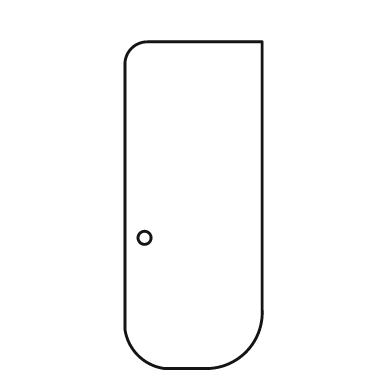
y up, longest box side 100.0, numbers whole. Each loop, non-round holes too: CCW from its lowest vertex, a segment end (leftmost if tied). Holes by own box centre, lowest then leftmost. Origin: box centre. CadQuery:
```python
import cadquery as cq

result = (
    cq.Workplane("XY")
    .moveTo(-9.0, -50.0)
    .lineTo(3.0, -50.0)
    .threePointArc((16.0, -45.0), (21.0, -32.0))
    .lineTo(21.0, 50.0)
    .lineTo(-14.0, 50.0)
    .threePointArc((-19.0, 48.0), (-21.0, 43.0))
    .lineTo(-21.0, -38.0)
    .threePointArc((-17.0, -46.0), (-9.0, -50.0))
    .close()
    .moveTo(-15.0, -10.0)
    .circle(2.0)
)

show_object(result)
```